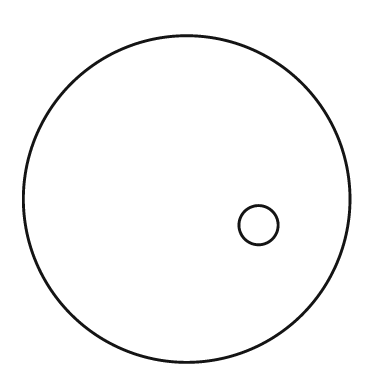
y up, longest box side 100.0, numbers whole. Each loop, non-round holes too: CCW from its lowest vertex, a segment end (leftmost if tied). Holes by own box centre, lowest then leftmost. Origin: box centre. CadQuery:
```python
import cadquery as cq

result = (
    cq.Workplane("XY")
    .moveTo(0.0, 0.0)
    .circle(50.0)
    .moveTo(22.0, -8.0)
    .circle(6.0)
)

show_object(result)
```